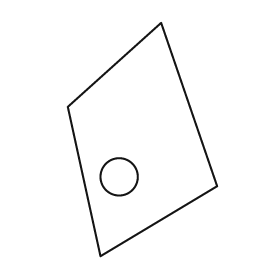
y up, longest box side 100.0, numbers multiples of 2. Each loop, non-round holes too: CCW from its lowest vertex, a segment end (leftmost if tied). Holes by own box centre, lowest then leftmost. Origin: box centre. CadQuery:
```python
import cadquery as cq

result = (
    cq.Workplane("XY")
    .moveTo(-18.0, -50.0)
    .lineTo(32.0, -20.0)
    .lineTo(8.0, 50.0)
    .lineTo(-32.0, 14.0)
    .close()
    .moveTo(-10.0, -16.0)
    .circle(8.0)
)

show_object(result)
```